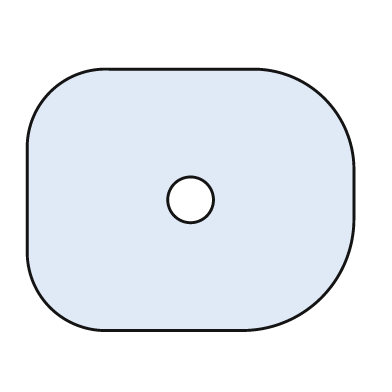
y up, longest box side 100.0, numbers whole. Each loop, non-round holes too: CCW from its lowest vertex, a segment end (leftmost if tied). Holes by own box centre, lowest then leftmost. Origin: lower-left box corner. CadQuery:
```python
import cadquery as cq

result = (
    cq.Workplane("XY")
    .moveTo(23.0, 0.0)
    .lineTo(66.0, 0.0)
    .threePointArc((90.0, 10.0), (100.0, 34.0))
    .lineTo(100.0, 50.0)
    .threePointArc((91.0, 71.0), (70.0, 80.0))
    .lineTo(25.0, 80.0)
    .threePointArc((7.0, 73.0), (0.0, 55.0))
    .lineTo(0.0, 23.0)
    .threePointArc((7.0, 7.0), (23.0, 0.0))
    .close()
    .moveTo(50.0, 40.0)
    .circle(7.0)
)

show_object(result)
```